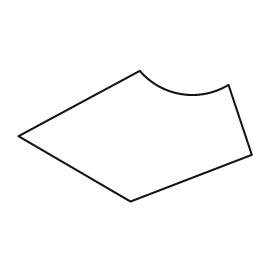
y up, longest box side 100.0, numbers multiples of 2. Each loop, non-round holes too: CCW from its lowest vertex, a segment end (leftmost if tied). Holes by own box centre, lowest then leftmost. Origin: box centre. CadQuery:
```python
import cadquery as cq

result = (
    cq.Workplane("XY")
    .moveTo(-2.0, -28.0)
    .lineTo(50.0, -8.0)
    .lineTo(40.0, 22.0)
    .threePointArc((20.0, 18.0), (2.0, 28.0))
    .lineTo(-50.0, 0.0)
    .close()
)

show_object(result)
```